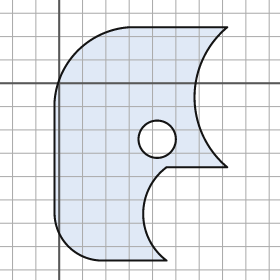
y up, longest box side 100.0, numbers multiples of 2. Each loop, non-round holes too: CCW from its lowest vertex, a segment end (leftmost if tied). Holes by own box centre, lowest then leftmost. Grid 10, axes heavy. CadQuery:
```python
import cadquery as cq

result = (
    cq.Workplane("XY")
    .moveTo(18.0, -76.0)
    .lineTo(46.0, -76.0)
    .threePointArc((36.0, -56.0), (46.0, -36.0))
    .lineTo(72.0, -36.0)
    .threePointArc((58.0, -6.0), (72.0, 24.0))
    .lineTo(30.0, 24.0)
    .threePointArc((8.0, 14.0), (-2.0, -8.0))
    .lineTo(-2.0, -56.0)
    .threePointArc((4.0, -70.0), (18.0, -76.0))
    .close()
    .moveTo(42.0, -24.0)
    .circle(8.0)
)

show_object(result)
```